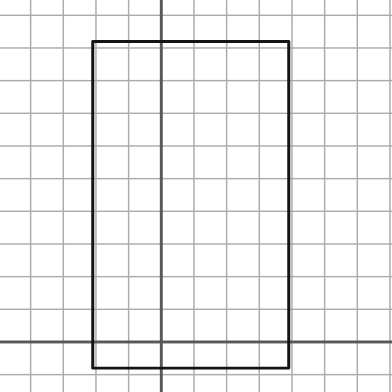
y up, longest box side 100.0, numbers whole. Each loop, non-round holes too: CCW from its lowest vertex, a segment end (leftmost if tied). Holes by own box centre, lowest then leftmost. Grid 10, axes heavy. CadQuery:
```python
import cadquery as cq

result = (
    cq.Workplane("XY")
    .moveTo(-21.0, -8.0)
    .lineTo(39.0, -8.0)
    .lineTo(39.0, 92.0)
    .lineTo(-21.0, 92.0)
    .close()
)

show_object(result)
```